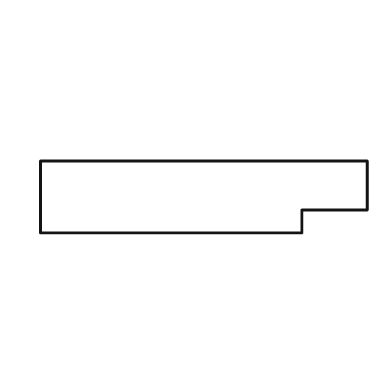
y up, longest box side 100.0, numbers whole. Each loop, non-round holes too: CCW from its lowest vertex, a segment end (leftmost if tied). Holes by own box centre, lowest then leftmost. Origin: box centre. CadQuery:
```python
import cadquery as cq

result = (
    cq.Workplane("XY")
    .moveTo(-50.0, -11.0)
    .lineTo(30.0, -11.0)
    .lineTo(30.0, -4.0)
    .lineTo(50.0, -4.0)
    .lineTo(50.0, 11.0)
    .lineTo(-50.0, 11.0)
    .close()
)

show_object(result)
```